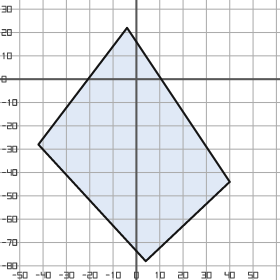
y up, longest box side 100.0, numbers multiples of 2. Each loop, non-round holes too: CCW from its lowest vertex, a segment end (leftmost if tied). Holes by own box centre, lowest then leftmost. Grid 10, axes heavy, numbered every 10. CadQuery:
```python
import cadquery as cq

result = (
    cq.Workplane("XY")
    .moveTo(4.0, -78.0)
    .lineTo(40.0, -44.0)
    .lineTo(-4.0, 22.0)
    .lineTo(-42.0, -28.0)
    .close()
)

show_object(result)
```